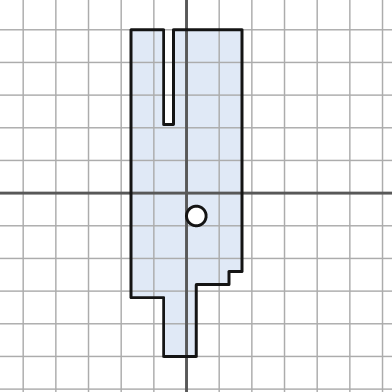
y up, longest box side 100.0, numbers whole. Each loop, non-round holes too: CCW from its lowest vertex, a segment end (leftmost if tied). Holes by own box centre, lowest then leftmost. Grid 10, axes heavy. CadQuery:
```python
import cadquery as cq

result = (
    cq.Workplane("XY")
    .moveTo(-7.0, -50.0)
    .lineTo(3.0, -50.0)
    .lineTo(3.0, -28.0)
    .lineTo(13.0, -28.0)
    .lineTo(13.0, -24.0)
    .lineTo(17.0, -24.0)
    .lineTo(17.0, 50.0)
    .lineTo(-4.0, 50.0)
    .lineTo(-4.0, 21.0)
    .lineTo(-7.0, 21.0)
    .lineTo(-7.0, 50.0)
    .lineTo(-17.0, 50.0)
    .lineTo(-17.0, -32.0)
    .lineTo(-7.0, -32.0)
    .close()
    .moveTo(3.0, -7.0)
    .circle(3.0)
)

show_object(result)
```